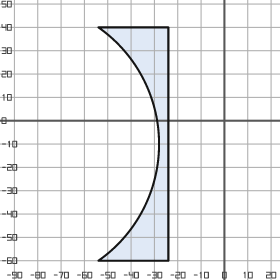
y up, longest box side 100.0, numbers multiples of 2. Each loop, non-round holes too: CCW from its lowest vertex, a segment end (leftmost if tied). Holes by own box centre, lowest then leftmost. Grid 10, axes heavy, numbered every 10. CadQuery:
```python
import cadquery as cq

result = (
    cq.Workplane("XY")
    .moveTo(-54.0, -60.0)
    .lineTo(-24.0, -60.0)
    .lineTo(-24.0, 40.0)
    .lineTo(-54.0, 40.0)
    .threePointArc((-28.0, -10.0), (-54.0, -60.0))
    .close()
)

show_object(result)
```